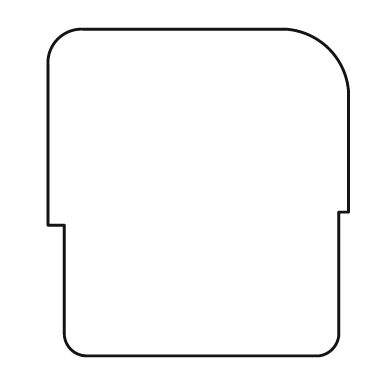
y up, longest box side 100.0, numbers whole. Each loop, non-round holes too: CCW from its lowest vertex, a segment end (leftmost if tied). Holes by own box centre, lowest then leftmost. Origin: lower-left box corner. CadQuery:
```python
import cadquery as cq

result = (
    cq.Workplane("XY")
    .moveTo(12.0, 0.0)
    .lineTo(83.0, 0.0)
    .threePointArc((87.0, 2.0), (89.0, 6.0))
    .lineTo(89.0, 44.0)
    .lineTo(92.0, 44.0)
    .lineTo(92.0, 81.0)
    .threePointArc((86.0, 94.0), (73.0, 100.0))
    .lineTo(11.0, 100.0)
    .threePointArc((3.0, 97.0), (0.0, 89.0))
    .lineTo(0.0, 40.0)
    .lineTo(5.0, 40.0)
    .lineTo(5.0, 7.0)
    .threePointArc((7.0, 2.0), (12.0, 0.0))
    .close()
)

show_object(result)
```